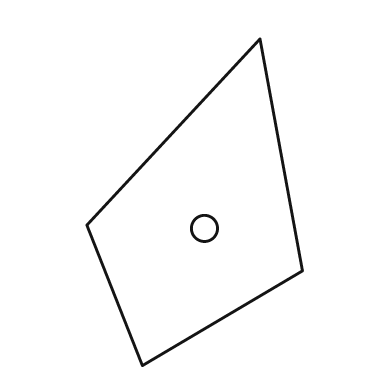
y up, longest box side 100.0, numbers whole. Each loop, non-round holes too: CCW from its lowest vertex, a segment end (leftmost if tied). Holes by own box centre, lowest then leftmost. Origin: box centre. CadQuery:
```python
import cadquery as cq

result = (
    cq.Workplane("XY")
    .moveTo(-16.0, -50.0)
    .lineTo(33.0, -21.0)
    .lineTo(20.0, 50.0)
    .lineTo(-33.0, -7.0)
    .close()
    .moveTo(3.0, -8.0)
    .circle(4.0)
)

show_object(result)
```